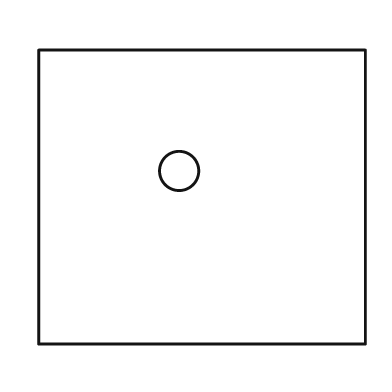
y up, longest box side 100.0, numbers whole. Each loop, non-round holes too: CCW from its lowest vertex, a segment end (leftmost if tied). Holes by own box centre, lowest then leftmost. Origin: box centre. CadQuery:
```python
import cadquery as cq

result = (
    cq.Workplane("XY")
    .moveTo(-50.0, -45.0)
    .lineTo(50.0, -45.0)
    .lineTo(50.0, 45.0)
    .lineTo(-50.0, 45.0)
    .close()
    .moveTo(-7.0, 8.0)
    .circle(6.0)
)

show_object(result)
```